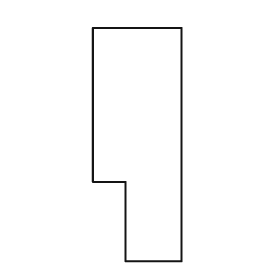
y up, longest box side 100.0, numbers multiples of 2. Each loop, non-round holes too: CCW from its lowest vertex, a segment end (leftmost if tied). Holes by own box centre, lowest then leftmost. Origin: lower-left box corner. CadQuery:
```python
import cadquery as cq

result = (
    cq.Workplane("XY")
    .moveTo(14.0, 0.0)
    .lineTo(38.0, 0.0)
    .lineTo(38.0, 100.0)
    .lineTo(0.0, 100.0)
    .lineTo(0.0, 34.0)
    .lineTo(14.0, 34.0)
    .close()
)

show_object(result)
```